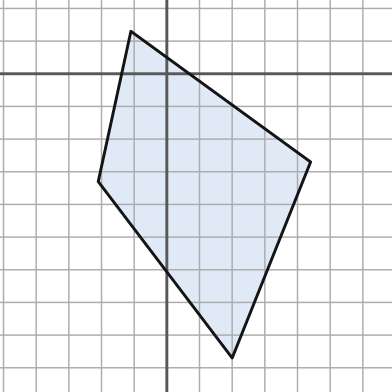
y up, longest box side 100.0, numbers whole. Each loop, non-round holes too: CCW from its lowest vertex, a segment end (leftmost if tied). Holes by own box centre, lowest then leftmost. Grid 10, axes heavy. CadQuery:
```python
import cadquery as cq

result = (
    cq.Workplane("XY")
    .moveTo(20.0, -87.0)
    .lineTo(44.0, -27.0)
    .lineTo(-11.0, 13.0)
    .lineTo(-21.0, -33.0)
    .close()
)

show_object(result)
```